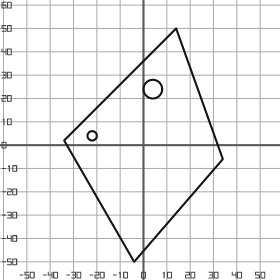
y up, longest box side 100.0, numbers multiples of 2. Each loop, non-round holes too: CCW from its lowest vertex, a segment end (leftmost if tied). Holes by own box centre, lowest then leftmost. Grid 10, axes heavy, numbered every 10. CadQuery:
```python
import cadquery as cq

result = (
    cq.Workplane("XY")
    .moveTo(-4.0, -50.0)
    .lineTo(34.0, -6.0)
    .lineTo(14.0, 50.0)
    .lineTo(-34.0, 2.0)
    .close()
    .moveTo(-22.0, 4.0)
    .circle(2.0)
    .moveTo(4.0, 24.0)
    .circle(4.0)
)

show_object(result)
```